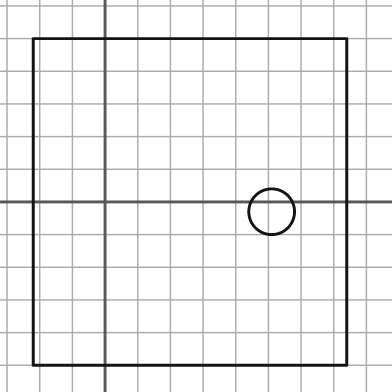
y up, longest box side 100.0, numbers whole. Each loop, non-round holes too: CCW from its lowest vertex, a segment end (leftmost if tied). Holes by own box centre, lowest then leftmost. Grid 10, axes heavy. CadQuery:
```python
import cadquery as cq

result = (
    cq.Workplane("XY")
    .moveTo(-22.0, -50.0)
    .lineTo(74.0, -50.0)
    .lineTo(74.0, 50.0)
    .lineTo(-22.0, 50.0)
    .close()
    .moveTo(51.0, -3.0)
    .circle(7.0)
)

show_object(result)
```